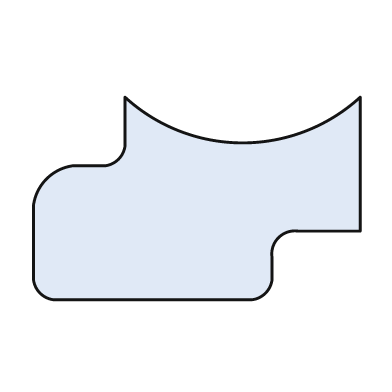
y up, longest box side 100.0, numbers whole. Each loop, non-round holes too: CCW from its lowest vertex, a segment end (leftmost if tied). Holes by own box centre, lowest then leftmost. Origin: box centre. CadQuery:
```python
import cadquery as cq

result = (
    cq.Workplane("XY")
    .moveTo(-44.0, -31.0)
    .lineTo(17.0, -31.0)
    .threePointArc((21.0, -29.0), (23.0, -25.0))
    .lineTo(23.0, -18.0)
    .threePointArc((25.0, -12.0), (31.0, -10.0))
    .lineTo(50.0, -10.0)
    .lineTo(50.0, 31.0)
    .threePointArc((14.0, 17.0), (-22.0, 31.0))
    .lineTo(-22.0, 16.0)
    .threePointArc((-24.0, 12.0), (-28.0, 10.0))
    .lineTo(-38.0, 10.0)
    .threePointArc((-46.0, 6.0), (-50.0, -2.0))
    .lineTo(-50.0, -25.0)
    .threePointArc((-48.0, -29.0), (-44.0, -31.0))
    .close()
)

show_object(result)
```